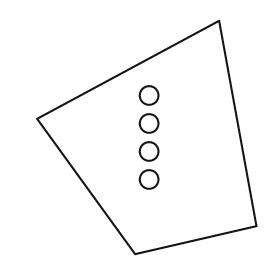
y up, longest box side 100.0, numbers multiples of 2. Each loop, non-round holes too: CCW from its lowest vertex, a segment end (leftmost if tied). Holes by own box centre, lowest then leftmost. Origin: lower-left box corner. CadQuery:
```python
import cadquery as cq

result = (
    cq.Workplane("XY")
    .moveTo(42.0, 0.0)
    .lineTo(94.0, 12.0)
    .lineTo(78.0, 100.0)
    .lineTo(0.0, 58.0)
    .close()
    .moveTo(48.0, 32.0)
    .circle(4.0)
    .moveTo(48.0, 44.0)
    .circle(4.0)
    .moveTo(48.0, 56.0)
    .circle(4.0)
    .moveTo(48.0, 68.0)
    .circle(4.0)
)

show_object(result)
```